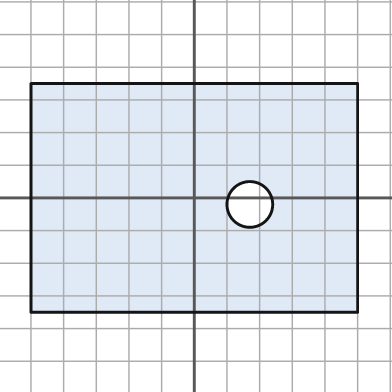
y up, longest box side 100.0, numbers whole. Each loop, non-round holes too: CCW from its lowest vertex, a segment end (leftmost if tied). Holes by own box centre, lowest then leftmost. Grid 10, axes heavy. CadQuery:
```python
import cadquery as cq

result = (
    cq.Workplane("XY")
    .moveTo(-50.0, -35.0)
    .lineTo(50.0, -35.0)
    .lineTo(50.0, 35.0)
    .lineTo(-50.0, 35.0)
    .close()
    .moveTo(17.0, -2.0)
    .circle(7.0)
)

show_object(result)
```